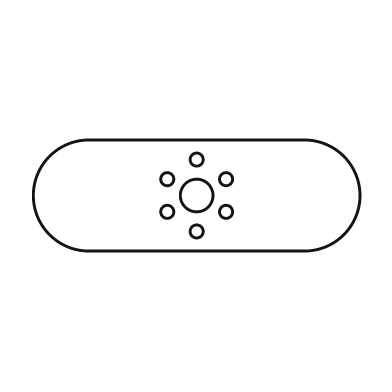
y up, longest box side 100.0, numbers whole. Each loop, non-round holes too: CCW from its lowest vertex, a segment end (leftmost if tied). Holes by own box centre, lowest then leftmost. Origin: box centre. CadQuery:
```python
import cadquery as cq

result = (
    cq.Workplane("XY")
    .moveTo(-33.0, -17.0)
    .lineTo(33.0, -17.0)
    .threePointArc((50.0, 0.0), (33.0, 17.0))
    .lineTo(-33.0, 17.0)
    .threePointArc((-50.0, 0.0), (-33.0, -17.0))
    .close()
    .moveTo(0.0, -11.0)
    .circle(2.0)
    .moveTo(-9.0, -5.0)
    .circle(2.0)
    .moveTo(9.0, -5.0)
    .circle(2.0)
    .moveTo(0.0, 0.0)
    .circle(5.0)
    .moveTo(-9.0, 5.0)
    .circle(2.0)
    .moveTo(9.0, 5.0)
    .circle(2.0)
    .moveTo(0.0, 11.0)
    .circle(2.0)
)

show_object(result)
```